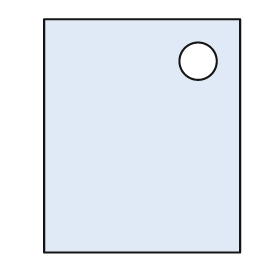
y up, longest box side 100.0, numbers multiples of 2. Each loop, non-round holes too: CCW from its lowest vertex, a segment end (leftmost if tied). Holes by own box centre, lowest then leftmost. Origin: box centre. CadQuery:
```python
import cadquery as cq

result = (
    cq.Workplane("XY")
    .moveTo(-42.0, -50.0)
    .lineTo(42.0, -50.0)
    .lineTo(42.0, 50.0)
    .lineTo(-42.0, 50.0)
    .close()
    .moveTo(24.0, 32.0)
    .circle(8.0)
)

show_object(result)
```